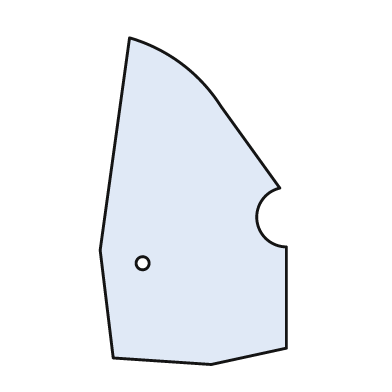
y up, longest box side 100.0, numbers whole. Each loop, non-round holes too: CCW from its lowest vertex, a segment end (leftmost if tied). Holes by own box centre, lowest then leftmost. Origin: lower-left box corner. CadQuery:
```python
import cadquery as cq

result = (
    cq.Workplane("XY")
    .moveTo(34.0, 0.0)
    .lineTo(57.0, 5.0)
    .lineTo(57.0, 36.0)
    .threePointArc((48.0, 44.0), (55.0, 54.0))
    .lineTo(37.0, 79.0)
    .threePointArc((25.0, 92.0), (9.0, 100.0))
    .lineTo(0.0, 35.0)
    .lineTo(4.0, 2.0)
    .close()
    .moveTo(13.0, 31.0)
    .circle(2.0)
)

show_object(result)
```